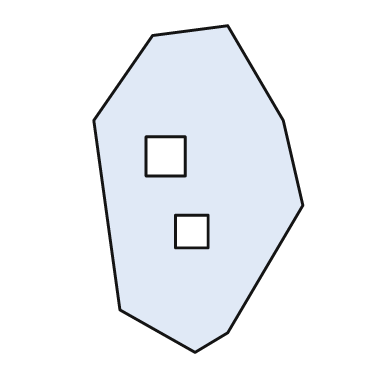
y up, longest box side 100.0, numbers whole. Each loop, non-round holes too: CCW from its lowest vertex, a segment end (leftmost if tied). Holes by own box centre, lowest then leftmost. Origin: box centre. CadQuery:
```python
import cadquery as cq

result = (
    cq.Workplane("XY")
    .moveTo(-1.0, -50.0)
    .lineTo(9.0, -44.0)
    .lineTo(32.0, -5.0)
    .lineTo(26.0, 21.0)
    .lineTo(9.0, 50.0)
    .lineTo(-14.0, 47.0)
    .lineTo(-32.0, 21.0)
    .lineTo(-24.0, -37.0)
    .close()
    .moveTo(-7.0, -18.0)
    .lineTo(3.0, -18.0)
    .lineTo(3.0, -8.0)
    .lineTo(-7.0, -8.0)
    .close()
    .moveTo(-16.0, 4.0)
    .lineTo(-4.0, 4.0)
    .lineTo(-4.0, 16.0)
    .lineTo(-16.0, 16.0)
    .close()
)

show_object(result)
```